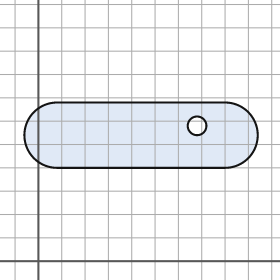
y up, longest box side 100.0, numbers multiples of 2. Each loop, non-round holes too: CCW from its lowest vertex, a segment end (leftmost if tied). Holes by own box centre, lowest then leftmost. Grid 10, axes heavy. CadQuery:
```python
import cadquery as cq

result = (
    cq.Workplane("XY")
    .moveTo(8.0, 40.0)
    .lineTo(80.0, 40.0)
    .threePointArc((94.0, 54.0), (80.0, 68.0))
    .lineTo(8.0, 68.0)
    .threePointArc((-6.0, 54.0), (8.0, 40.0))
    .close()
    .moveTo(68.0, 58.0)
    .circle(4.0)
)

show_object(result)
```